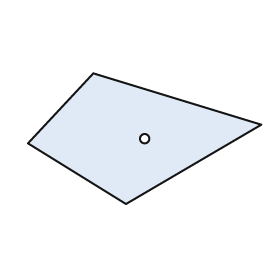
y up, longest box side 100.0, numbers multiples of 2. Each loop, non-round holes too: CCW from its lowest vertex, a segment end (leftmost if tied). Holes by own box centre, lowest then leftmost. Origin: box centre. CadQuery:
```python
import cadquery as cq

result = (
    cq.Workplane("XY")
    .moveTo(-8.0, -28.0)
    .lineTo(50.0, 6.0)
    .lineTo(-22.0, 28.0)
    .lineTo(-50.0, -2.0)
    .close()
    .moveTo(0.0, 0.0)
    .circle(2.0)
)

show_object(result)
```